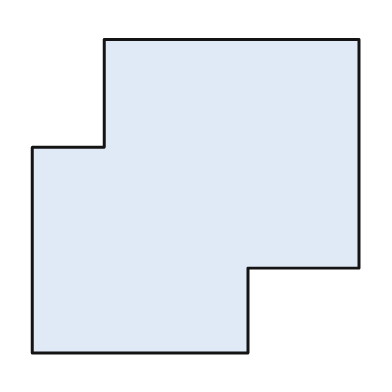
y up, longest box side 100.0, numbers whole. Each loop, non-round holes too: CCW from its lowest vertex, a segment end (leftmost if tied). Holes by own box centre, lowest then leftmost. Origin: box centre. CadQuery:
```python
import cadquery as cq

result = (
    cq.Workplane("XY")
    .moveTo(-50.0, -48.0)
    .lineTo(16.0, -48.0)
    .lineTo(16.0, -22.0)
    .lineTo(50.0, -22.0)
    .lineTo(50.0, 48.0)
    .lineTo(-28.0, 48.0)
    .lineTo(-28.0, 15.0)
    .lineTo(-50.0, 15.0)
    .close()
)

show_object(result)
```